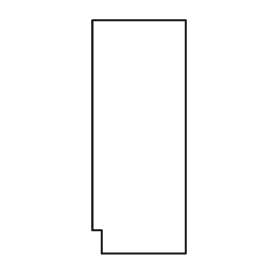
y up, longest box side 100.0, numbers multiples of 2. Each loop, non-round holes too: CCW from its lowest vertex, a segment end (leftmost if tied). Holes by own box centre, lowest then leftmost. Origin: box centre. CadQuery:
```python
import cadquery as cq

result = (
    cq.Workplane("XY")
    .moveTo(-16.0, -50.0)
    .lineTo(20.0, -50.0)
    .lineTo(20.0, 50.0)
    .lineTo(-20.0, 50.0)
    .lineTo(-20.0, -40.0)
    .lineTo(-16.0, -40.0)
    .close()
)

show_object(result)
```